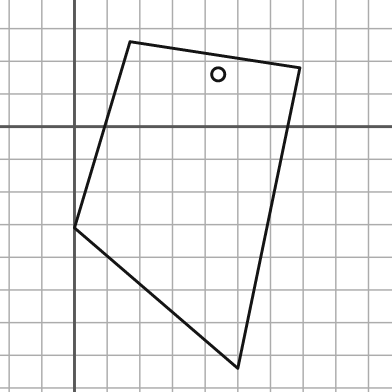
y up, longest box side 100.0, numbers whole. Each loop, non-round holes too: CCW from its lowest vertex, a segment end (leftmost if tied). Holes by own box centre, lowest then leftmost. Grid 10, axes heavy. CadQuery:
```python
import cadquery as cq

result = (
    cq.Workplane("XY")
    .moveTo(50.0, -74.0)
    .lineTo(69.0, 18.0)
    .lineTo(17.0, 26.0)
    .lineTo(0.0, -31.0)
    .close()
    .moveTo(44.0, 16.0)
    .circle(2.0)
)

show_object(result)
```